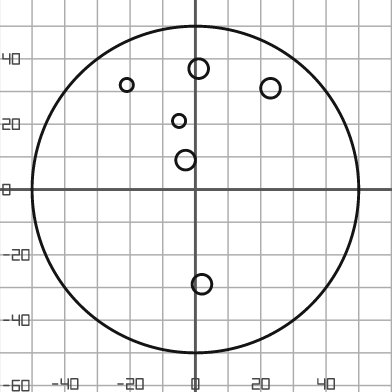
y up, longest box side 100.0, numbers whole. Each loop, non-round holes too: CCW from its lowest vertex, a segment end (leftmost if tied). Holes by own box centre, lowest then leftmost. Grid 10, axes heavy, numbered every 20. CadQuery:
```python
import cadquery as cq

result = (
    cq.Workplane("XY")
    .moveTo(0.0, 0.0)
    .circle(50.0)
    .moveTo(2.0, -29.0)
    .circle(3.0)
    .moveTo(-3.0, 9.0)
    .circle(3.0)
    .moveTo(-5.0, 21.0)
    .circle(2.0)
    .moveTo(23.0, 31.0)
    .circle(3.0)
    .moveTo(-21.0, 32.0)
    .circle(2.0)
    .moveTo(1.0, 37.0)
    .circle(3.0)
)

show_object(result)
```